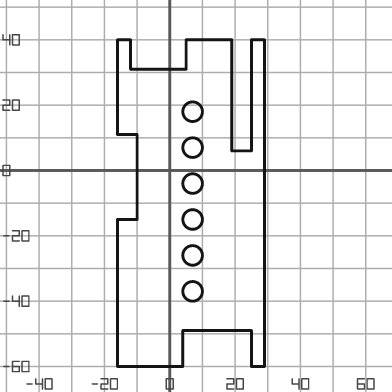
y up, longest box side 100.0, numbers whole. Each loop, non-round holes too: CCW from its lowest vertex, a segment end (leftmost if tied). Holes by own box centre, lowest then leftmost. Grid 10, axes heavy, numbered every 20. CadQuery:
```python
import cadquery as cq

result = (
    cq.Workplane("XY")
    .moveTo(-16.0, -60.0)
    .lineTo(4.0, -60.0)
    .lineTo(4.0, -49.0)
    .lineTo(25.0, -49.0)
    .lineTo(25.0, -60.0)
    .lineTo(29.0, -60.0)
    .lineTo(29.0, 40.0)
    .lineTo(25.0, 40.0)
    .lineTo(25.0, 6.0)
    .lineTo(19.0, 6.0)
    .lineTo(19.0, 40.0)
    .lineTo(5.0, 40.0)
    .lineTo(5.0, 31.0)
    .lineTo(-12.0, 31.0)
    .lineTo(-12.0, 40.0)
    .lineTo(-16.0, 40.0)
    .lineTo(-16.0, 11.0)
    .lineTo(-10.0, 11.0)
    .lineTo(-10.0, -15.0)
    .lineTo(-16.0, -15.0)
    .close()
    .moveTo(7.0, -37.0)
    .circle(3.0)
    .moveTo(7.0, -26.0)
    .circle(3.0)
    .moveTo(7.0, -15.0)
    .circle(3.0)
    .moveTo(7.0, -4.0)
    .circle(3.0)
    .moveTo(7.0, 7.0)
    .circle(3.0)
    .moveTo(7.0, 18.0)
    .circle(3.0)
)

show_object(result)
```